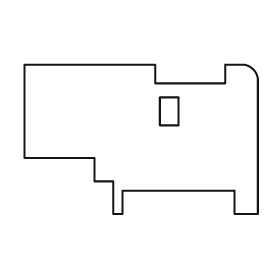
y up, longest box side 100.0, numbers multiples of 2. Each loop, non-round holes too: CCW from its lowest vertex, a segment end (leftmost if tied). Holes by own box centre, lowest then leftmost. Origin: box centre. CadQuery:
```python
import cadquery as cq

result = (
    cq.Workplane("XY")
    .moveTo(-12.0, -32.0)
    .lineTo(-8.0, -32.0)
    .lineTo(-8.0, -22.0)
    .lineTo(40.0, -22.0)
    .lineTo(40.0, -32.0)
    .lineTo(50.0, -32.0)
    .lineTo(50.0, 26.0)
    .threePointArc((48.0, 30.0), (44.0, 32.0))
    .lineTo(36.0, 32.0)
    .lineTo(36.0, 24.0)
    .lineTo(6.0, 24.0)
    .lineTo(6.0, 32.0)
    .lineTo(-50.0, 32.0)
    .lineTo(-50.0, -8.0)
    .lineTo(-20.0, -8.0)
    .lineTo(-20.0, -18.0)
    .lineTo(-12.0, -18.0)
    .close()
    .moveTo(8.0, 6.0)
    .lineTo(16.0, 6.0)
    .lineTo(16.0, 18.0)
    .lineTo(8.0, 18.0)
    .close()
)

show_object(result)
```